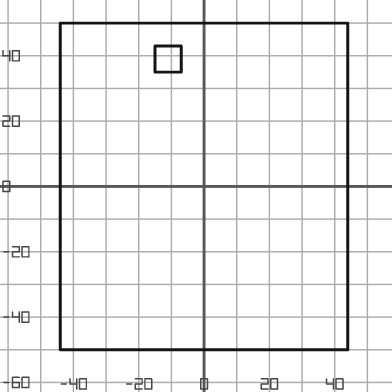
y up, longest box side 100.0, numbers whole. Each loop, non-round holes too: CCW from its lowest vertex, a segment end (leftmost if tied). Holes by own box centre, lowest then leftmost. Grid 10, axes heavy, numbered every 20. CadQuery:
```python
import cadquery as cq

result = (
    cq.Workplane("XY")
    .moveTo(-44.0, -50.0)
    .lineTo(44.0, -50.0)
    .lineTo(44.0, 50.0)
    .lineTo(-44.0, 50.0)
    .close()
    .moveTo(-15.0, 35.0)
    .lineTo(-7.0, 35.0)
    .lineTo(-7.0, 43.0)
    .lineTo(-15.0, 43.0)
    .close()
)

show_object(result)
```